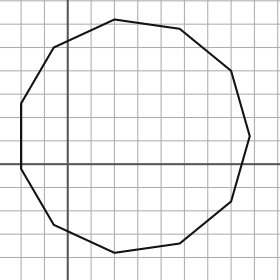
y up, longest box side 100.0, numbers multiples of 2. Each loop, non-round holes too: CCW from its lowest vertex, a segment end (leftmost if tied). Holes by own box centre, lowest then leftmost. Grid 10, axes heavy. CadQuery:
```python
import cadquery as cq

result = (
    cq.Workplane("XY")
    .moveTo(20.0, -38.0)
    .lineTo(48.0, -34.0)
    .lineTo(70.0, -16.0)
    .lineTo(78.0, 12.0)
    .lineTo(70.0, 40.0)
    .lineTo(48.0, 58.0)
    .lineTo(20.0, 62.0)
    .lineTo(-6.0, 50.0)
    .lineTo(-20.0, 26.0)
    .lineTo(-20.0, -2.0)
    .lineTo(-6.0, -26.0)
    .close()
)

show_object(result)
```